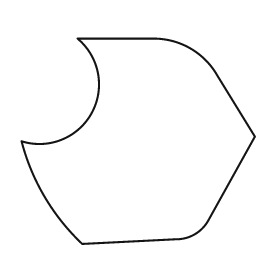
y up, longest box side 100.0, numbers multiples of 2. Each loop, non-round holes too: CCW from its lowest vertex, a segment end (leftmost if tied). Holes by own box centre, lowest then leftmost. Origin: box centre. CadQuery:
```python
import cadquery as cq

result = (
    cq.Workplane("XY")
    .moveTo(-24.0, -44.0)
    .lineTo(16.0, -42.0)
    .threePointArc((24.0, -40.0), (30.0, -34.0))
    .lineTo(50.0, 2.0)
    .lineTo(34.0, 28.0)
    .threePointArc((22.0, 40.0), (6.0, 44.0))
    .lineTo(-26.0, 44.0)
    .threePointArc((-20.0, 12.0), (-50.0, 0.0))
    .threePointArc((-40.0, -24.0), (-24.0, -44.0))
    .close()
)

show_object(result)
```